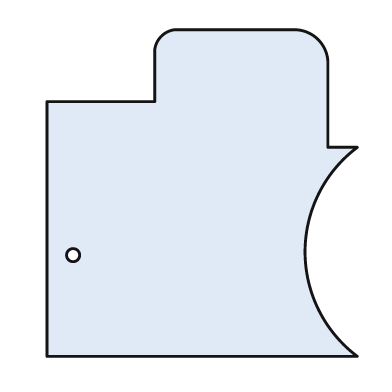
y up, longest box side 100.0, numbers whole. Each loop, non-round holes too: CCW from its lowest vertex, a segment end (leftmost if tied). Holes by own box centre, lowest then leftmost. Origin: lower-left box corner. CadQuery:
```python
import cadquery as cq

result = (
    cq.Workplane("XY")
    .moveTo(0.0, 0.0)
    .lineTo(95.0, 0.0)
    .threePointArc((79.0, 32.0), (95.0, 64.0))
    .lineTo(86.0, 64.0)
    .lineTo(86.0, 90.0)
    .threePointArc((83.0, 97.0), (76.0, 100.0))
    .lineTo(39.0, 100.0)
    .threePointArc((35.0, 98.0), (33.0, 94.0))
    .lineTo(33.0, 78.0)
    .lineTo(0.0, 78.0)
    .close()
    .moveTo(8.0, 31.0)
    .circle(2.0)
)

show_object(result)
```